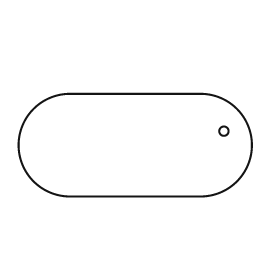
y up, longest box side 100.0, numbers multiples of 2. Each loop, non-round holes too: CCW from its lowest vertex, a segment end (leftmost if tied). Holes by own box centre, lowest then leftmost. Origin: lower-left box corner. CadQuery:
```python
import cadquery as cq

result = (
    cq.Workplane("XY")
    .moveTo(22.0, 0.0)
    .lineTo(78.0, 0.0)
    .threePointArc((100.0, 22.0), (78.0, 44.0))
    .lineTo(22.0, 44.0)
    .threePointArc((0.0, 22.0), (22.0, 0.0))
    .close()
    .moveTo(88.0, 28.0)
    .circle(2.0)
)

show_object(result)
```